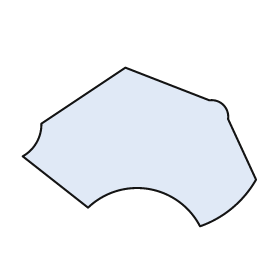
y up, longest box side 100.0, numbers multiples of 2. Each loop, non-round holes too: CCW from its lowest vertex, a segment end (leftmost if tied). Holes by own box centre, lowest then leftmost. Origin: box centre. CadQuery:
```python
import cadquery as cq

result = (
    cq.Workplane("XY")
    .moveTo(26.0, -34.0)
    .threePointArc((40.0, -26.0), (50.0, -14.0))
    .lineTo(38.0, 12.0)
    .threePointArc((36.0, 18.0), (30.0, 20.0))
    .lineTo(-6.0, 34.0)
    .lineTo(-42.0, 10.0)
    .threePointArc((-44.0, 2.0), (-50.0, -4.0))
    .lineTo(-22.0, -26.0)
    .threePointArc((4.0, -18.0), (26.0, -34.0))
    .close()
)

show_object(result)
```